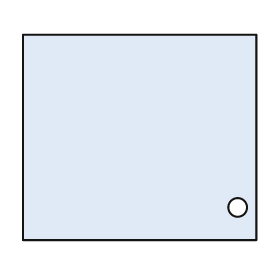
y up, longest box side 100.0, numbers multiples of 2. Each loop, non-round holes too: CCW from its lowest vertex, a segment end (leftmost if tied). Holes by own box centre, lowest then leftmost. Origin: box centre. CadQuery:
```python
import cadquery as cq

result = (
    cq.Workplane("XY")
    .moveTo(-50.0, -44.0)
    .lineTo(50.0, -44.0)
    .lineTo(50.0, 44.0)
    .lineTo(-50.0, 44.0)
    .close()
    .moveTo(42.0, -30.0)
    .circle(4.0)
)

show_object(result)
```